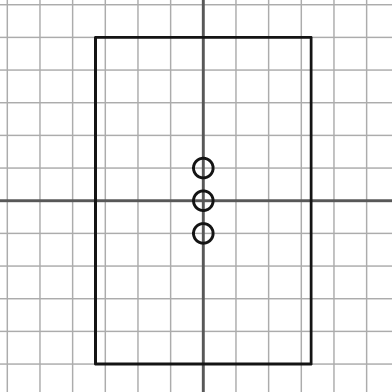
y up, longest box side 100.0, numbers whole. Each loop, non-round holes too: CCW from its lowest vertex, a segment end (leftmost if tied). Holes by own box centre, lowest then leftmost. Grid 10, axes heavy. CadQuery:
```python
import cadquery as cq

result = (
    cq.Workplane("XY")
    .moveTo(-33.0, -50.0)
    .lineTo(33.0, -50.0)
    .lineTo(33.0, 50.0)
    .lineTo(-33.0, 50.0)
    .close()
    .moveTo(0.0, -10.0)
    .circle(3.0)
    .moveTo(0.0, 0.0)
    .circle(3.0)
    .moveTo(0.0, 10.0)
    .circle(3.0)
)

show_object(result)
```